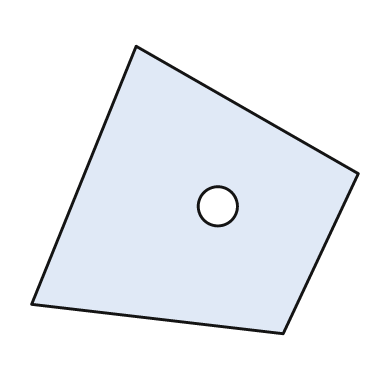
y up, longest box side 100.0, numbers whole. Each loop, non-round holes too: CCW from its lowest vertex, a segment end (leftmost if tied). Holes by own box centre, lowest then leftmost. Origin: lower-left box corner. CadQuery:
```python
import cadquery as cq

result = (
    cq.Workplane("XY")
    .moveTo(77.0, 0.0)
    .lineTo(100.0, 49.0)
    .lineTo(32.0, 88.0)
    .lineTo(0.0, 9.0)
    .close()
    .moveTo(57.0, 39.0)
    .circle(6.0)
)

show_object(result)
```